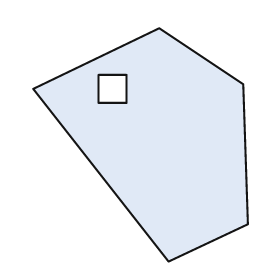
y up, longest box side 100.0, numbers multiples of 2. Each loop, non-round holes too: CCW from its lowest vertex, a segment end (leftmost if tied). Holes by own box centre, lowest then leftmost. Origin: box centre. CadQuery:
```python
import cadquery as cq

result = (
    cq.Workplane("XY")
    .moveTo(12.0, -50.0)
    .lineTo(46.0, -34.0)
    .lineTo(44.0, 26.0)
    .lineTo(8.0, 50.0)
    .lineTo(-46.0, 24.0)
    .close()
    .moveTo(-18.0, 18.0)
    .lineTo(-6.0, 18.0)
    .lineTo(-6.0, 30.0)
    .lineTo(-18.0, 30.0)
    .close()
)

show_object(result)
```